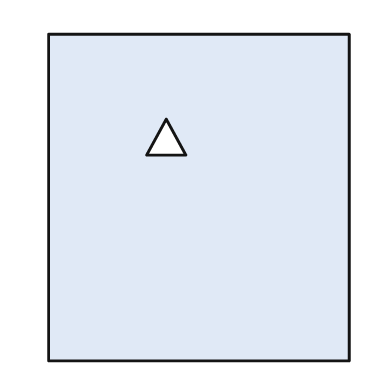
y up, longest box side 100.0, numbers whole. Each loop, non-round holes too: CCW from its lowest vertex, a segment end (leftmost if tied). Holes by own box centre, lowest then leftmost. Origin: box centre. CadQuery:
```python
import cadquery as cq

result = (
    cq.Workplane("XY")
    .moveTo(-46.0, -50.0)
    .lineTo(46.0, -50.0)
    .lineTo(46.0, 50.0)
    .lineTo(-46.0, 50.0)
    .close()
    .moveTo(-16.0, 13.0)
    .lineTo(-4.0, 13.0)
    .lineTo(-10.0, 24.0)
    .close()
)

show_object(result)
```